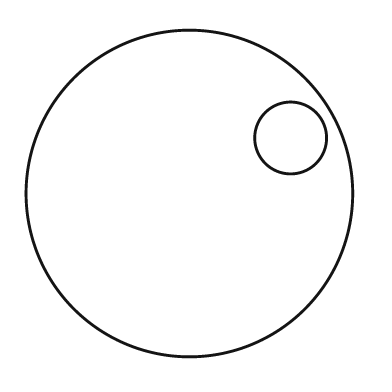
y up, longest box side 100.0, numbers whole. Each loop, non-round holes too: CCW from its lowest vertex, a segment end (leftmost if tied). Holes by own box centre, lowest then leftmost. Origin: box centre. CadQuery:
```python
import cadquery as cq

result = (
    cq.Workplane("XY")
    .moveTo(0.0, 0.0)
    .circle(50.0)
    .moveTo(31.0, 17.0)
    .circle(11.0)
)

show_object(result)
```